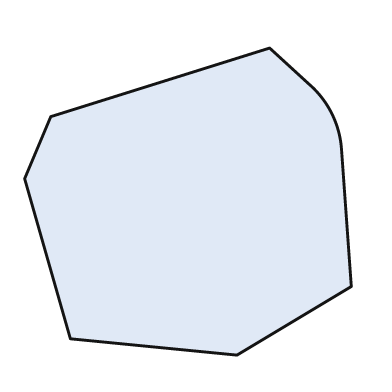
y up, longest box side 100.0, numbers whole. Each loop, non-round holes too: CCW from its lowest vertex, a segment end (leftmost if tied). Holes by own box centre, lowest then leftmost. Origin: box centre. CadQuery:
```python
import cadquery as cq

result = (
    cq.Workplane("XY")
    .moveTo(15.0, -47.0)
    .lineTo(50.0, -26.0)
    .lineTo(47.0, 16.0)
    .threePointArc((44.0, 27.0), (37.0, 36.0))
    .lineTo(25.0, 47.0)
    .lineTo(-42.0, 26.0)
    .lineTo(-50.0, 7.0)
    .lineTo(-36.0, -42.0)
    .close()
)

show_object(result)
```